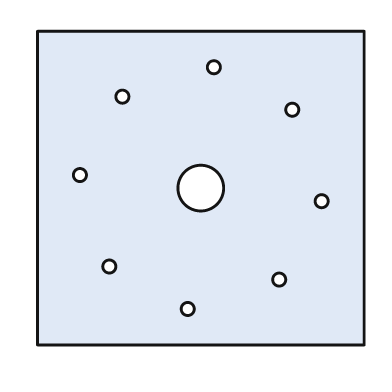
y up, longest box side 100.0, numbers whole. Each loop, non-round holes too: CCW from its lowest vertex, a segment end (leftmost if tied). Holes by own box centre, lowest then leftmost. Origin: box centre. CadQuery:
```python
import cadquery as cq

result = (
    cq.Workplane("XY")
    .moveTo(-50.0, -48.0)
    .lineTo(50.0, -48.0)
    .lineTo(50.0, 48.0)
    .lineTo(-50.0, 48.0)
    .close()
    .moveTo(-4.0, -37.0)
    .circle(2.0)
    .moveTo(24.0, -28.0)
    .circle(2.0)
    .moveTo(-28.0, -24.0)
    .circle(2.0)
    .moveTo(37.0, -4.0)
    .circle(2.0)
    .moveTo(0.0, 0.0)
    .circle(7.0)
    .moveTo(-37.0, 4.0)
    .circle(2.0)
    .moveTo(28.0, 24.0)
    .circle(2.0)
    .moveTo(-24.0, 28.0)
    .circle(2.0)
    .moveTo(4.0, 37.0)
    .circle(2.0)
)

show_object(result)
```